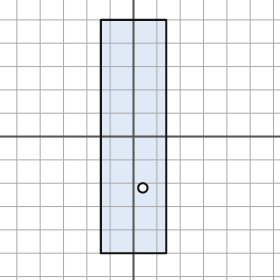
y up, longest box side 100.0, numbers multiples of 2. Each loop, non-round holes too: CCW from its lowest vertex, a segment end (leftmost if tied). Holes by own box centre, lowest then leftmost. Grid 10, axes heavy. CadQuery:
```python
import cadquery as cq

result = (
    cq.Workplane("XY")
    .moveTo(-14.0, -50.0)
    .lineTo(14.0, -50.0)
    .lineTo(14.0, 50.0)
    .lineTo(-14.0, 50.0)
    .close()
    .moveTo(4.0, -22.0)
    .circle(2.0)
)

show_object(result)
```